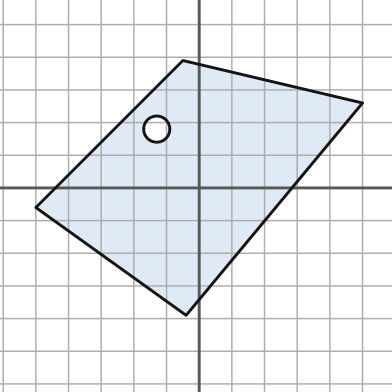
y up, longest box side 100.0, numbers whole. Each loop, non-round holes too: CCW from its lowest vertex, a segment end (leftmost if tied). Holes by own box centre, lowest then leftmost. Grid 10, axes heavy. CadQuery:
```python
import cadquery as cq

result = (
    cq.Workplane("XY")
    .moveTo(-4.0, -39.0)
    .lineTo(50.0, 26.0)
    .lineTo(-5.0, 39.0)
    .lineTo(-50.0, -6.0)
    .close()
    .moveTo(-13.0, 18.0)
    .circle(4.0)
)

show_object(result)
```